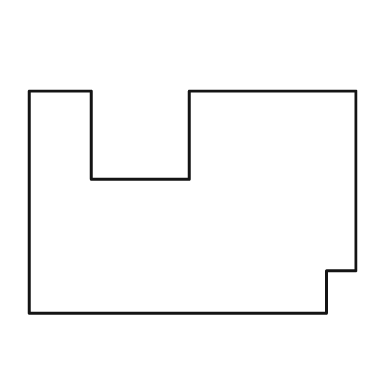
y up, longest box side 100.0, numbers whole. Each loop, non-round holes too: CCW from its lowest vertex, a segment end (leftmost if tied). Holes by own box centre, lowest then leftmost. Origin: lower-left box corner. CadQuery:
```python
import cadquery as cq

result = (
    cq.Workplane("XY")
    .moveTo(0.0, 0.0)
    .lineTo(91.0, 0.0)
    .lineTo(91.0, 13.0)
    .lineTo(100.0, 13.0)
    .lineTo(100.0, 68.0)
    .lineTo(49.0, 68.0)
    .lineTo(49.0, 41.0)
    .lineTo(19.0, 41.0)
    .lineTo(19.0, 68.0)
    .lineTo(0.0, 68.0)
    .close()
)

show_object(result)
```